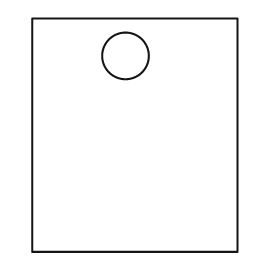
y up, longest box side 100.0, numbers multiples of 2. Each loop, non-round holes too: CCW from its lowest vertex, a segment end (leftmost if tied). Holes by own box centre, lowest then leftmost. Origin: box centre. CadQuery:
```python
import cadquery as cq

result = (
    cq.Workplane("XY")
    .moveTo(-44.0, -50.0)
    .lineTo(44.0, -50.0)
    .lineTo(44.0, 50.0)
    .lineTo(-44.0, 50.0)
    .close()
    .moveTo(-4.0, 34.0)
    .circle(10.0)
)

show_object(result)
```